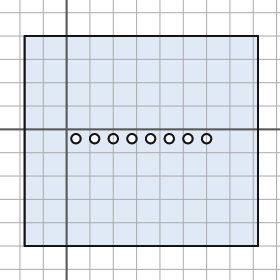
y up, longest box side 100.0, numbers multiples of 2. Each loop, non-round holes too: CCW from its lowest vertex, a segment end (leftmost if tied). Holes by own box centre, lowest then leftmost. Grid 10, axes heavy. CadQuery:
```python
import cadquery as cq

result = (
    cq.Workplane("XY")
    .moveTo(-18.0, -50.0)
    .lineTo(82.0, -50.0)
    .lineTo(82.0, 40.0)
    .lineTo(-18.0, 40.0)
    .close()
    .moveTo(4.0, -4.0)
    .circle(2.0)
    .moveTo(12.0, -4.0)
    .circle(2.0)
    .moveTo(20.0, -4.0)
    .circle(2.0)
    .moveTo(28.0, -4.0)
    .circle(2.0)
    .moveTo(36.0, -4.0)
    .circle(2.0)
    .moveTo(44.0, -4.0)
    .circle(2.0)
    .moveTo(52.0, -4.0)
    .circle(2.0)
    .moveTo(60.0, -4.0)
    .circle(2.0)
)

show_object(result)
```